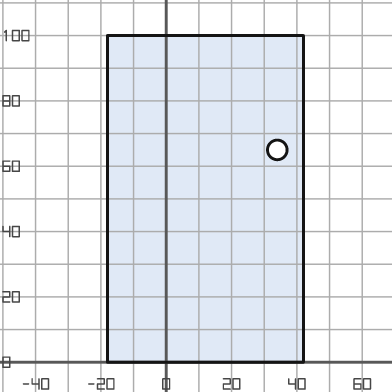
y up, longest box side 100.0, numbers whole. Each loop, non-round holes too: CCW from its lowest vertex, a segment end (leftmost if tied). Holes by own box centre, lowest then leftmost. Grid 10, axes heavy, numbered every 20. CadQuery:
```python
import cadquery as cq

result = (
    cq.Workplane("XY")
    .moveTo(-18.0, 0.0)
    .lineTo(42.0, 0.0)
    .lineTo(42.0, 100.0)
    .lineTo(-18.0, 100.0)
    .close()
    .moveTo(34.0, 65.0)
    .circle(3.0)
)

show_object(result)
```